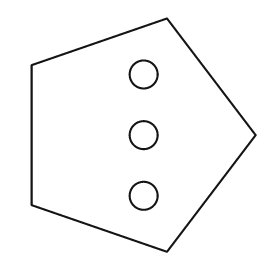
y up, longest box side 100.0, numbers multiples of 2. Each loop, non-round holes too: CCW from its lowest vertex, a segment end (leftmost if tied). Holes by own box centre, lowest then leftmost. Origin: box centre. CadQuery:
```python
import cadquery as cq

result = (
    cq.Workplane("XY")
    .moveTo(10.0, -50.0)
    .lineTo(48.0, 0.0)
    .lineTo(10.0, 50.0)
    .lineTo(-48.0, 30.0)
    .lineTo(-48.0, -30.0)
    .close()
    .moveTo(0.0, -26.0)
    .circle(6.0)
    .moveTo(0.0, 0.0)
    .circle(6.0)
    .moveTo(0.0, 26.0)
    .circle(6.0)
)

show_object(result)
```